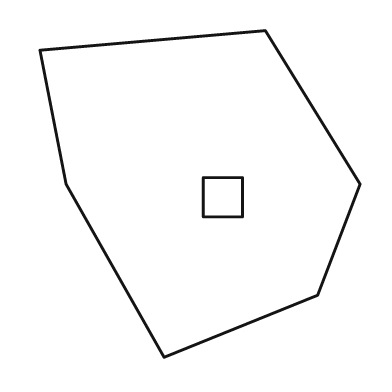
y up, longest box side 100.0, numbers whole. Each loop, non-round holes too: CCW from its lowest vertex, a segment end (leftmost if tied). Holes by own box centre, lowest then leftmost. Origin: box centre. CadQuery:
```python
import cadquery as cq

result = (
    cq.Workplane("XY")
    .moveTo(-11.0, -50.0)
    .lineTo(36.0, -31.0)
    .lineTo(49.0, 3.0)
    .lineTo(20.0, 50.0)
    .lineTo(-49.0, 44.0)
    .lineTo(-41.0, 3.0)
    .close()
    .moveTo(1.0, -7.0)
    .lineTo(13.0, -7.0)
    .lineTo(13.0, 5.0)
    .lineTo(1.0, 5.0)
    .close()
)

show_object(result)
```